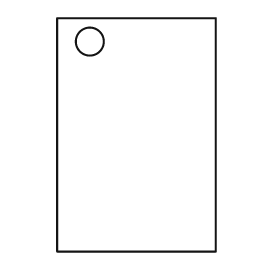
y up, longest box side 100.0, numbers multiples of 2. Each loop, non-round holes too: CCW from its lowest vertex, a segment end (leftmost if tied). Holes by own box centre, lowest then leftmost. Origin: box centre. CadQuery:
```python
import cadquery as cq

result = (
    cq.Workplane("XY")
    .moveTo(-34.0, -50.0)
    .lineTo(34.0, -50.0)
    .lineTo(34.0, 50.0)
    .lineTo(-34.0, 50.0)
    .close()
    .moveTo(-20.0, 40.0)
    .circle(6.0)
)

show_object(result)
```